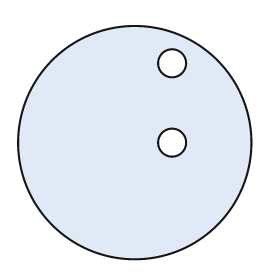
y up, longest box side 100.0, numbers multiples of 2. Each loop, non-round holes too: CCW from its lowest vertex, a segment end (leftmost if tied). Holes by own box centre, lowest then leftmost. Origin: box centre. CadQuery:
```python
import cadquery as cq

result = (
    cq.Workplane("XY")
    .moveTo(0.0, 0.0)
    .circle(50.0)
    .moveTo(16.0, 0.0)
    .circle(6.0)
    .moveTo(16.0, 34.0)
    .circle(6.0)
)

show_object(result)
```